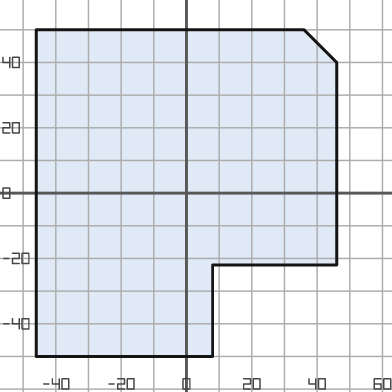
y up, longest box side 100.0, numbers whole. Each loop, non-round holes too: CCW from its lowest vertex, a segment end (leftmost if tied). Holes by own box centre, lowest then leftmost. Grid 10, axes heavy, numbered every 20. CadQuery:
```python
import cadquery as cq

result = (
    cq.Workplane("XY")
    .moveTo(-46.0, -50.0)
    .lineTo(8.0, -50.0)
    .lineTo(8.0, -22.0)
    .lineTo(46.0, -22.0)
    .lineTo(46.0, 40.0)
    .lineTo(36.0, 50.0)
    .lineTo(-46.0, 50.0)
    .close()
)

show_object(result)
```